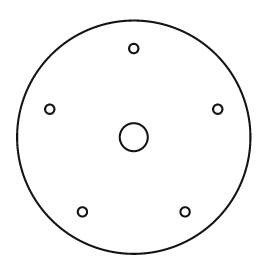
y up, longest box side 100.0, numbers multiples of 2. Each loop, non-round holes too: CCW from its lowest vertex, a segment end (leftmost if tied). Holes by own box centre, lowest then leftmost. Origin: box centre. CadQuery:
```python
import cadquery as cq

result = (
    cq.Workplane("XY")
    .moveTo(0.0, 0.0)
    .circle(50.0)
    .moveTo(-22.0, -32.0)
    .circle(2.0)
    .moveTo(22.0, -32.0)
    .circle(2.0)
    .moveTo(0.0, 0.0)
    .circle(6.0)
    .moveTo(-36.0, 12.0)
    .circle(2.0)
    .moveTo(36.0, 12.0)
    .circle(2.0)
    .moveTo(0.0, 38.0)
    .circle(2.0)
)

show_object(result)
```